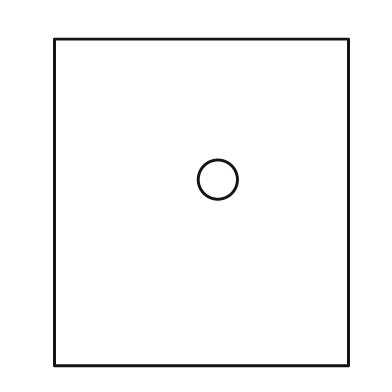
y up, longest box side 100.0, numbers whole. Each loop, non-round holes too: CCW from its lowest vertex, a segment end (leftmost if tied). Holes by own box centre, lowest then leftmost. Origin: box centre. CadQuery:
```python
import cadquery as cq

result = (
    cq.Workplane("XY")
    .moveTo(-45.0, -50.0)
    .lineTo(45.0, -50.0)
    .lineTo(45.0, 50.0)
    .lineTo(-45.0, 50.0)
    .close()
    .moveTo(5.0, 7.0)
    .circle(6.0)
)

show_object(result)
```